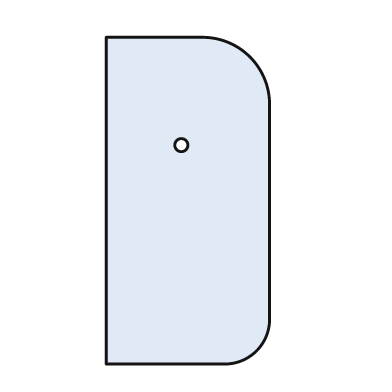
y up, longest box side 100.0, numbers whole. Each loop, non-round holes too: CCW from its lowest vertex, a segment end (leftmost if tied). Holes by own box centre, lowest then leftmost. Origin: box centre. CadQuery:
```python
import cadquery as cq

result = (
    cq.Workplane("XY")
    .moveTo(-25.0, -50.0)
    .lineTo(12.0, -50.0)
    .threePointArc((21.0, -46.0), (25.0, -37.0))
    .lineTo(25.0, 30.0)
    .threePointArc((19.0, 44.0), (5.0, 50.0))
    .lineTo(-25.0, 50.0)
    .close()
    .moveTo(-2.0, 17.0)
    .circle(2.0)
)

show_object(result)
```